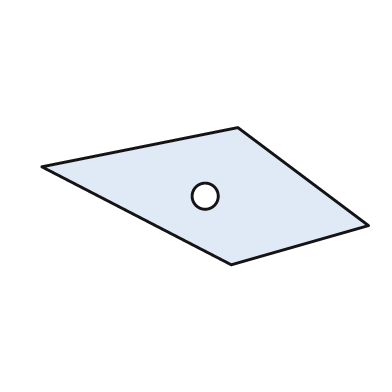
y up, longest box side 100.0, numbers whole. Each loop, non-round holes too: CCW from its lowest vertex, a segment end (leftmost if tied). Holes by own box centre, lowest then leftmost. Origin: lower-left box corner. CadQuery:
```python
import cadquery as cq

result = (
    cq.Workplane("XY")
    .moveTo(58.0, 0.0)
    .lineTo(100.0, 12.0)
    .lineTo(60.0, 42.0)
    .lineTo(0.0, 30.0)
    .close()
    .moveTo(50.0, 21.0)
    .circle(4.0)
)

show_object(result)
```